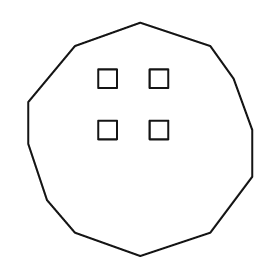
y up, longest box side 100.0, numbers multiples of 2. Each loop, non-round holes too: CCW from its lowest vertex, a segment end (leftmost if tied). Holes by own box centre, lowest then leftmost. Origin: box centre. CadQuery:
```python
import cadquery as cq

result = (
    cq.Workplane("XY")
    .moveTo(0.0, -50.0)
    .lineTo(30.0, -40.0)
    .lineTo(48.0, -16.0)
    .lineTo(48.0, 4.0)
    .lineTo(40.0, 26.0)
    .lineTo(30.0, 40.0)
    .lineTo(0.0, 50.0)
    .lineTo(-28.0, 40.0)
    .lineTo(-48.0, 16.0)
    .lineTo(-48.0, -2.0)
    .lineTo(-40.0, -26.0)
    .lineTo(-28.0, -40.0)
    .close()
    .moveTo(-18.0, 0.0)
    .lineTo(-10.0, 0.0)
    .lineTo(-10.0, 8.0)
    .lineTo(-18.0, 8.0)
    .close()
    .moveTo(4.0, 0.0)
    .lineTo(12.0, 0.0)
    .lineTo(12.0, 8.0)
    .lineTo(4.0, 8.0)
    .close()
    .moveTo(-18.0, 22.0)
    .lineTo(-10.0, 22.0)
    .lineTo(-10.0, 30.0)
    .lineTo(-18.0, 30.0)
    .close()
    .moveTo(4.0, 22.0)
    .lineTo(12.0, 22.0)
    .lineTo(12.0, 30.0)
    .lineTo(4.0, 30.0)
    .close()
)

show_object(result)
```